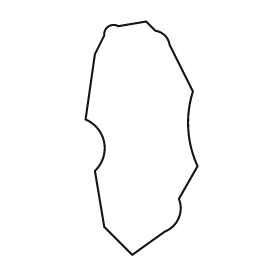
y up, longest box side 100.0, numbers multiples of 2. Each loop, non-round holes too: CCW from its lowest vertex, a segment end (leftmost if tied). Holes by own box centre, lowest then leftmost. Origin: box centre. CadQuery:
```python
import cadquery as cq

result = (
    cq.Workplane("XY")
    .moveTo(-4.0, -50.0)
    .lineTo(10.0, -40.0)
    .threePointArc((16.0, -34.0), (16.0, -26.0))
    .lineTo(24.0, -12.0)
    .threePointArc((20.0, 4.0), (22.0, 20.0))
    .lineTo(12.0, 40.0)
    .threePointArc((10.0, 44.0), (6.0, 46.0))
    .lineTo(2.0, 50.0)
    .lineTo(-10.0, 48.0)
    .threePointArc((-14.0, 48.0), (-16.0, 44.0))
    .lineTo(-20.0, 36.0)
    .lineTo(-24.0, 8.0)
    .threePointArc((-16.0, -2.0), (-20.0, -14.0))
    .lineTo(-16.0, -38.0)
    .close()
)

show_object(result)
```